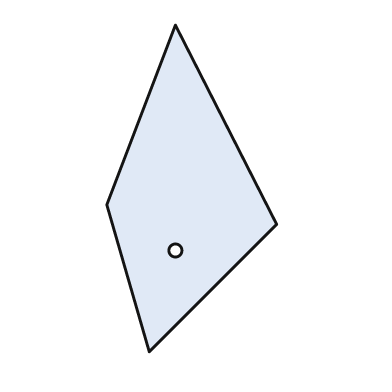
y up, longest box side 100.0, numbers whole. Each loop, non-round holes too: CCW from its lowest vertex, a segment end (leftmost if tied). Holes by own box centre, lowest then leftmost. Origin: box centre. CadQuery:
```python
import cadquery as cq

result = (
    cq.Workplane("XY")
    .moveTo(-13.0, -50.0)
    .lineTo(26.0, -11.0)
    .lineTo(-5.0, 50.0)
    .lineTo(-26.0, -5.0)
    .close()
    .moveTo(-5.0, -19.0)
    .circle(2.0)
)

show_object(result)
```